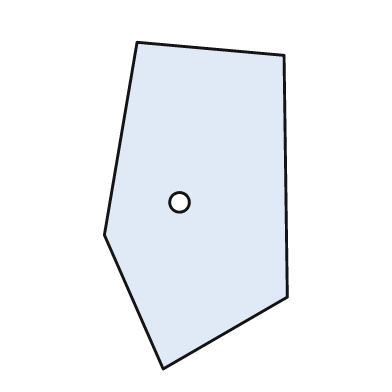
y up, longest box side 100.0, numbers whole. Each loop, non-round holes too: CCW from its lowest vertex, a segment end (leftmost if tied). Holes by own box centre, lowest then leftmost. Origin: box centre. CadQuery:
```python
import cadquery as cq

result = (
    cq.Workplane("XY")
    .moveTo(-10.0, -50.0)
    .lineTo(28.0, -28.0)
    .lineTo(27.0, 46.0)
    .lineTo(-18.0, 50.0)
    .lineTo(-28.0, -9.0)
    .close()
    .moveTo(-5.0, 1.0)
    .circle(3.0)
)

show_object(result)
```